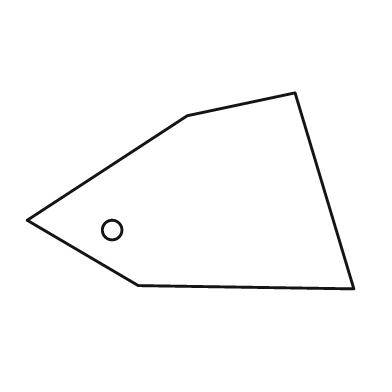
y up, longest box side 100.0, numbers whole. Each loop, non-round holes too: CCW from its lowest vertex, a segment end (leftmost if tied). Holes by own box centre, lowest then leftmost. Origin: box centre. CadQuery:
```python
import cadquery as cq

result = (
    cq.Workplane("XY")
    .moveTo(50.0, -30.0)
    .lineTo(32.0, 30.0)
    .lineTo(-1.0, 23.0)
    .lineTo(-50.0, -9.0)
    .lineTo(-16.0, -29.0)
    .close()
    .moveTo(-24.0, -12.0)
    .circle(3.0)
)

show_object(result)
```